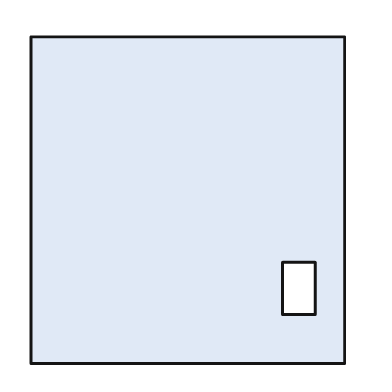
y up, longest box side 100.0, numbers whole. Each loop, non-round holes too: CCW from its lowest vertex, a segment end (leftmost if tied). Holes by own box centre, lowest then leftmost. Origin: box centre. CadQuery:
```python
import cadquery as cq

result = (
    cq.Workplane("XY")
    .moveTo(-48.0, -50.0)
    .lineTo(48.0, -50.0)
    .lineTo(48.0, 50.0)
    .lineTo(-48.0, 50.0)
    .close()
    .moveTo(29.0, -35.0)
    .lineTo(39.0, -35.0)
    .lineTo(39.0, -19.0)
    .lineTo(29.0, -19.0)
    .close()
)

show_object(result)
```